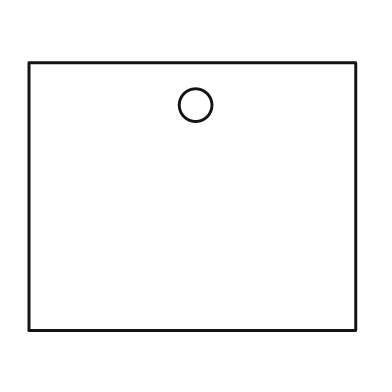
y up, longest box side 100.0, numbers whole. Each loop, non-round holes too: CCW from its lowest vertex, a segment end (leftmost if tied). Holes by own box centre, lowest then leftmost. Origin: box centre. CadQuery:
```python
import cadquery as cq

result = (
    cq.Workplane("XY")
    .moveTo(-50.0, -41.0)
    .lineTo(50.0, -41.0)
    .lineTo(50.0, 41.0)
    .lineTo(-50.0, 41.0)
    .close()
    .moveTo(1.0, 28.0)
    .circle(5.0)
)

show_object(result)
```